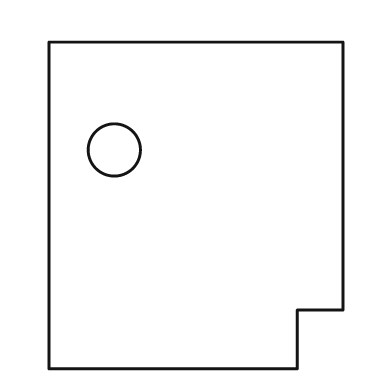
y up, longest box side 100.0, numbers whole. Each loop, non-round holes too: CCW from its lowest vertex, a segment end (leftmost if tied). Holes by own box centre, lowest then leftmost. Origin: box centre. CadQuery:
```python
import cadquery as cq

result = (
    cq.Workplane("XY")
    .moveTo(-45.0, -50.0)
    .lineTo(31.0, -50.0)
    .lineTo(31.0, -32.0)
    .lineTo(45.0, -32.0)
    .lineTo(45.0, 50.0)
    .lineTo(-45.0, 50.0)
    .close()
    .moveTo(-25.0, 17.0)
    .circle(8.0)
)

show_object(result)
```